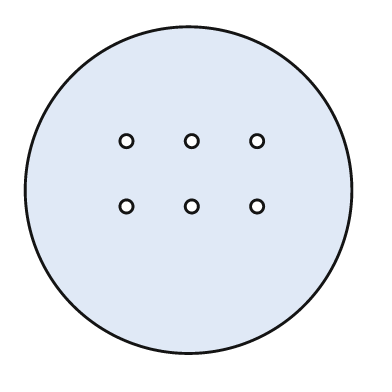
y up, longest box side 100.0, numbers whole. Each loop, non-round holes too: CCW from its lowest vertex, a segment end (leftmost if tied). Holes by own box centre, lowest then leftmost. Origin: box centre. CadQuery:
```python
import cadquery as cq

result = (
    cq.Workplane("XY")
    .moveTo(0.0, 0.0)
    .circle(50.0)
    .moveTo(-19.0, -5.0)
    .circle(2.0)
    .moveTo(1.0, -5.0)
    .circle(2.0)
    .moveTo(21.0, -5.0)
    .circle(2.0)
    .moveTo(-19.0, 15.0)
    .circle(2.0)
    .moveTo(1.0, 15.0)
    .circle(2.0)
    .moveTo(21.0, 15.0)
    .circle(2.0)
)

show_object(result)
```